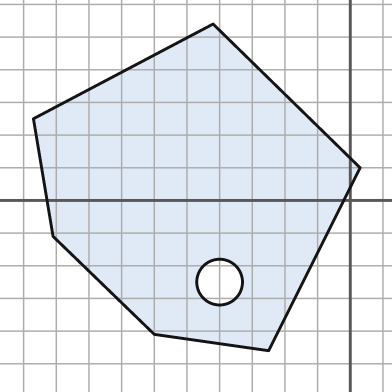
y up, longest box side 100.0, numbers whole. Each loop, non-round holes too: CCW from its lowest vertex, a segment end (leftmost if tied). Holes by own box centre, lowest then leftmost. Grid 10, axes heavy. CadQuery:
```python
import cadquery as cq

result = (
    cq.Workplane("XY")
    .moveTo(-25.0, -46.0)
    .lineTo(3.0, 10.0)
    .lineTo(-42.0, 54.0)
    .lineTo(-97.0, 25.0)
    .lineTo(-91.0, -11.0)
    .lineTo(-60.0, -41.0)
    .close()
    .moveTo(-40.0, -25.0)
    .circle(7.0)
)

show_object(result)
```